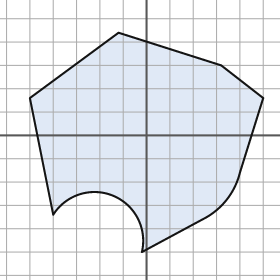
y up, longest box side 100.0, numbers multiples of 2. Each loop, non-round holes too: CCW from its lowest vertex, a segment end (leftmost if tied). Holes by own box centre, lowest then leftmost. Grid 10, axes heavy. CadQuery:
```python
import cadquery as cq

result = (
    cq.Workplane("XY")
    .moveTo(-2.0, -50.0)
    .lineTo(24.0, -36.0)
    .threePointArc((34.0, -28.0), (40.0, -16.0))
    .lineTo(50.0, 16.0)
    .lineTo(32.0, 30.0)
    .lineTo(-12.0, 44.0)
    .lineTo(-50.0, 16.0)
    .lineTo(-40.0, -34.0)
    .threePointArc((-14.0, -26.0), (-2.0, -50.0))
    .close()
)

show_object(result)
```